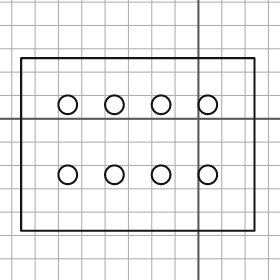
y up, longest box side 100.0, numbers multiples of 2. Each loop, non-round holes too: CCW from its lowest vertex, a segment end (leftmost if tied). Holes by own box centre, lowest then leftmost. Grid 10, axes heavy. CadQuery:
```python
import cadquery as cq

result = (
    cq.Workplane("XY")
    .moveTo(-76.0, -48.0)
    .lineTo(24.0, -48.0)
    .lineTo(24.0, 26.0)
    .lineTo(-76.0, 26.0)
    .close()
    .moveTo(-56.0, -24.0)
    .circle(4.0)
    .moveTo(-36.0, -24.0)
    .circle(4.0)
    .moveTo(-16.0, -24.0)
    .circle(4.0)
    .moveTo(4.0, -24.0)
    .circle(4.0)
    .moveTo(-56.0, 6.0)
    .circle(4.0)
    .moveTo(-36.0, 6.0)
    .circle(4.0)
    .moveTo(-16.0, 6.0)
    .circle(4.0)
    .moveTo(4.0, 6.0)
    .circle(4.0)
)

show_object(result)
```